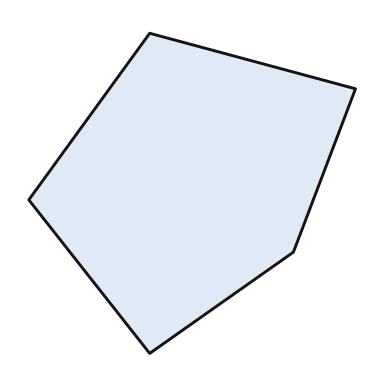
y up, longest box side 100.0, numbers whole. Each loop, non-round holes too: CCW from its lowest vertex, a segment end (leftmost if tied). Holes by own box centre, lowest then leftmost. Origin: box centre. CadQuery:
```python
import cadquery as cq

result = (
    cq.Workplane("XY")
    .moveTo(-13.0, -49.0)
    .lineTo(31.0, -18.0)
    .lineTo(50.0, 32.0)
    .lineTo(-13.0, 49.0)
    .lineTo(-50.0, -2.0)
    .close()
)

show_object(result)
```